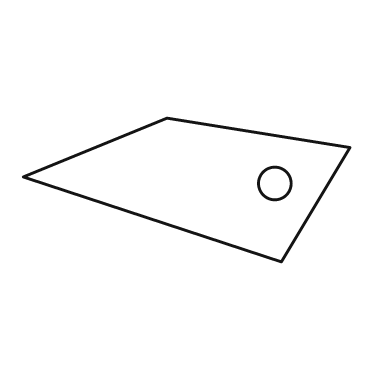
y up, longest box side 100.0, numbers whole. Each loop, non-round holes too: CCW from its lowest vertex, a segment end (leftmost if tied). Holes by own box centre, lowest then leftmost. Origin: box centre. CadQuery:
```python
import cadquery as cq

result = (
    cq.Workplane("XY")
    .moveTo(29.0, -22.0)
    .lineTo(50.0, 13.0)
    .lineTo(-6.0, 22.0)
    .lineTo(-50.0, 4.0)
    .close()
    .moveTo(27.0, 2.0)
    .circle(5.0)
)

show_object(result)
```